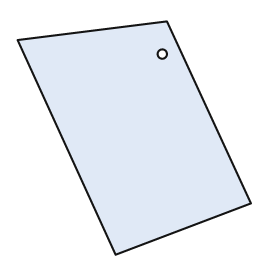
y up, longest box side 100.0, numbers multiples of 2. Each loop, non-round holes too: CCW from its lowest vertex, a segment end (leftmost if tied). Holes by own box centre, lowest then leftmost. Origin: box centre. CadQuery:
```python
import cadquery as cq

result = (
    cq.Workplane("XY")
    .moveTo(-8.0, -50.0)
    .lineTo(50.0, -28.0)
    .lineTo(14.0, 50.0)
    .lineTo(-50.0, 42.0)
    .close()
    .moveTo(12.0, 36.0)
    .circle(2.0)
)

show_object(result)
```